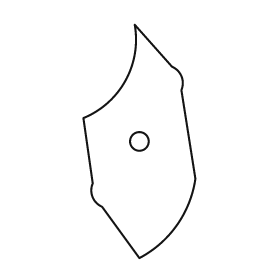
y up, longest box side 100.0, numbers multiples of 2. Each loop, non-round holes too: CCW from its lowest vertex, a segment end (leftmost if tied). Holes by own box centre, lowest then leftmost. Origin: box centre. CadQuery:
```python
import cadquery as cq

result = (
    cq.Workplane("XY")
    .moveTo(0.0, -50.0)
    .threePointArc((16.0, -36.0), (24.0, -16.0))
    .lineTo(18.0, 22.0)
    .threePointArc((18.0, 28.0), (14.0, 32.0))
    .lineTo(-2.0, 50.0)
    .threePointArc((-6.0, 26.0), (-24.0, 10.0))
    .lineTo(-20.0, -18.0)
    .threePointArc((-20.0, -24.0), (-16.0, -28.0))
    .close()
    .moveTo(0.0, 0.0)
    .circle(4.0)
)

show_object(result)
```